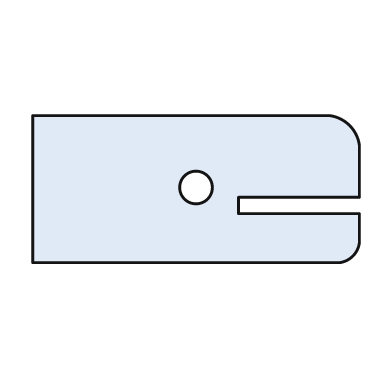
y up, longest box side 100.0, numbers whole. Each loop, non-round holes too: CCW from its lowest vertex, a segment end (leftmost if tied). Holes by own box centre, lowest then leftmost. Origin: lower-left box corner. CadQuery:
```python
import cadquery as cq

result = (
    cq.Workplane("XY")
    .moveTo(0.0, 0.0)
    .lineTo(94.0, 0.0)
    .threePointArc((98.0, 2.0), (100.0, 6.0))
    .lineTo(100.0, 15.0)
    .lineTo(63.0, 15.0)
    .lineTo(63.0, 20.0)
    .lineTo(100.0, 20.0)
    .lineTo(100.0, 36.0)
    .threePointArc((97.0, 42.0), (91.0, 45.0))
    .lineTo(0.0, 45.0)
    .close()
    .moveTo(50.0, 23.0)
    .circle(5.0)
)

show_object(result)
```